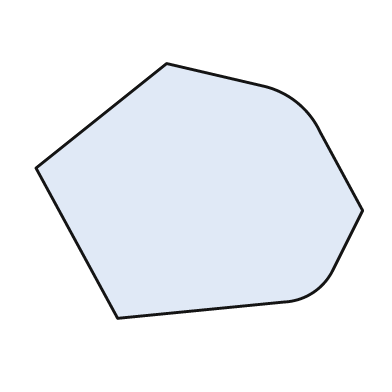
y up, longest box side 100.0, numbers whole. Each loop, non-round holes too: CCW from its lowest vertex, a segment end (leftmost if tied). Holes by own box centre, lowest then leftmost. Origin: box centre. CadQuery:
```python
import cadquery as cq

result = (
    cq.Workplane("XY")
    .moveTo(-25.0, -39.0)
    .lineTo(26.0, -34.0)
    .threePointArc((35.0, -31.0), (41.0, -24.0))
    .lineTo(50.0, -6.0)
    .lineTo(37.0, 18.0)
    .threePointArc((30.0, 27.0), (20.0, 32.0))
    .lineTo(-10.0, 39.0)
    .lineTo(-50.0, 7.0)
    .close()
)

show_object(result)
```